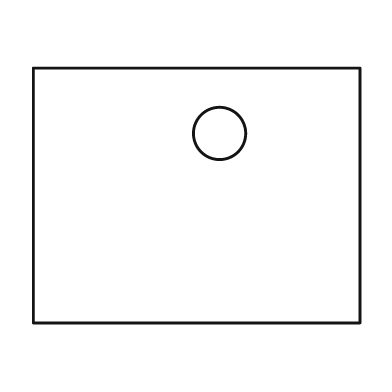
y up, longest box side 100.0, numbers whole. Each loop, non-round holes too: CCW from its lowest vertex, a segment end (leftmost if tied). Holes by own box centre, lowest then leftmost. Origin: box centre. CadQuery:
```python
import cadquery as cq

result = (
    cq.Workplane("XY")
    .moveTo(-50.0, -39.0)
    .lineTo(50.0, -39.0)
    .lineTo(50.0, 39.0)
    .lineTo(-50.0, 39.0)
    .close()
    .moveTo(7.0, 19.0)
    .circle(8.0)
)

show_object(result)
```